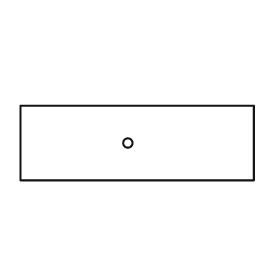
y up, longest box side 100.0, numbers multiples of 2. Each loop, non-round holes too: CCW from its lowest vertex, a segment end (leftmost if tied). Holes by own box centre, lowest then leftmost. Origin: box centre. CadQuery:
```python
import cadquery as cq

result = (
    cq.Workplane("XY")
    .moveTo(-50.0, -16.0)
    .lineTo(50.0, -16.0)
    .lineTo(50.0, 16.0)
    .lineTo(-50.0, 16.0)
    .close()
    .moveTo(-4.0, 0.0)
    .circle(2.0)
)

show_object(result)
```